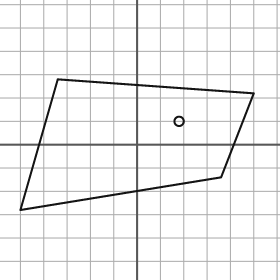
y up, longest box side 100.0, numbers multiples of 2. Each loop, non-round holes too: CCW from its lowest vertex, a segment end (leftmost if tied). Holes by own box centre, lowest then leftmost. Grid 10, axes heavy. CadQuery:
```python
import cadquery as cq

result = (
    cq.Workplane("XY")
    .moveTo(-50.0, -28.0)
    .lineTo(36.0, -14.0)
    .lineTo(50.0, 22.0)
    .lineTo(-34.0, 28.0)
    .close()
    .moveTo(18.0, 10.0)
    .circle(2.0)
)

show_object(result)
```